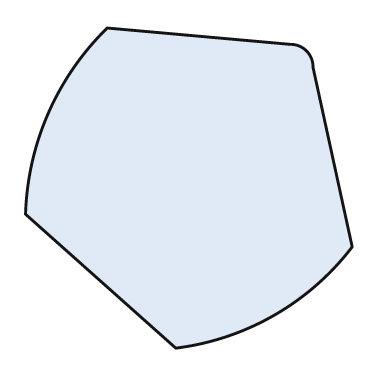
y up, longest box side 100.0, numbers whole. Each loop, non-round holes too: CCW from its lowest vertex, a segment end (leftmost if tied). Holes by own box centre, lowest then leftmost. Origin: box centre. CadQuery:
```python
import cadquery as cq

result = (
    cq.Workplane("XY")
    .moveTo(-4.0, -49.0)
    .threePointArc((26.0, -39.0), (50.0, -18.0))
    .lineTo(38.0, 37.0)
    .threePointArc((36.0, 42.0), (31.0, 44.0))
    .lineTo(-25.0, 49.0)
    .threePointArc((-43.0, 23.0), (-50.0, -8.0))
    .close()
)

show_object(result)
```